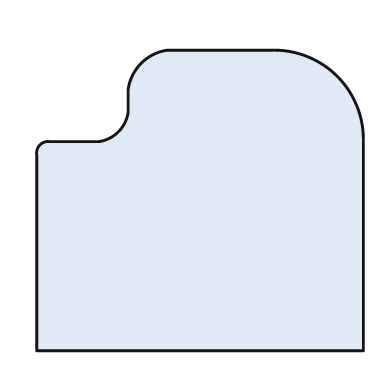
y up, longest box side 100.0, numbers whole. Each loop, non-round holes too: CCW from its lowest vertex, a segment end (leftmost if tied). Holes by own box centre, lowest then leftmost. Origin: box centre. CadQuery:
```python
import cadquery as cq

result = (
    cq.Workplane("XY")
    .moveTo(-50.0, -46.0)
    .lineTo(50.0, -46.0)
    .lineTo(50.0, 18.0)
    .threePointArc((42.0, 38.0), (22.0, 46.0))
    .lineTo(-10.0, 46.0)
    .threePointArc((-18.0, 42.0), (-22.0, 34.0))
    .lineTo(-22.0, 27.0)
    .threePointArc((-25.0, 21.0), (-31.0, 18.0))
    .lineTo(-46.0, 18.0)
    .threePointArc((-49.0, 17.0), (-50.0, 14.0))
    .close()
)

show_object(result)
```